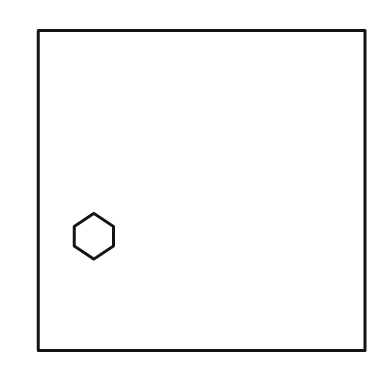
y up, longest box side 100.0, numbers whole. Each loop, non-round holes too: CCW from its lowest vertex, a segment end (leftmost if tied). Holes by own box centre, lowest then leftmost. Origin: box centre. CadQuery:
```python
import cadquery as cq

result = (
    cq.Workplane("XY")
    .moveTo(-50.0, -49.0)
    .lineTo(50.0, -49.0)
    .lineTo(50.0, 49.0)
    .lineTo(-50.0, 49.0)
    .close()
    .moveTo(-33.0, -21.0)
    .lineTo(-27.0, -17.0)
    .lineTo(-27.0, -11.0)
    .lineTo(-33.0, -7.0)
    .lineTo(-39.0, -11.0)
    .lineTo(-39.0, -17.0)
    .close()
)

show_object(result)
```